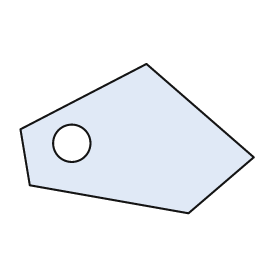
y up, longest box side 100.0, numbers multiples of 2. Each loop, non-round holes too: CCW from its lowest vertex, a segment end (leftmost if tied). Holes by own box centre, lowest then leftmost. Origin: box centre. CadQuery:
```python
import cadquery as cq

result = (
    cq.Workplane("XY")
    .moveTo(22.0, -32.0)
    .lineTo(50.0, -8.0)
    .lineTo(4.0, 32.0)
    .lineTo(-50.0, 4.0)
    .lineTo(-46.0, -20.0)
    .close()
    .moveTo(-28.0, -2.0)
    .circle(8.0)
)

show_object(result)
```